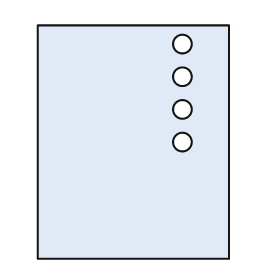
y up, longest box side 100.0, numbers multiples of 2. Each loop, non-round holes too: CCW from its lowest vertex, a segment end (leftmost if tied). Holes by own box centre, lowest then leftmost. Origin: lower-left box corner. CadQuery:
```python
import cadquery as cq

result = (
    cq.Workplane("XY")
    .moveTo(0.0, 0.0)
    .lineTo(82.0, 0.0)
    .lineTo(82.0, 100.0)
    .lineTo(0.0, 100.0)
    .close()
    .moveTo(62.0, 50.0)
    .circle(4.0)
    .moveTo(62.0, 64.0)
    .circle(4.0)
    .moveTo(62.0, 78.0)
    .circle(4.0)
    .moveTo(62.0, 92.0)
    .circle(4.0)
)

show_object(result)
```